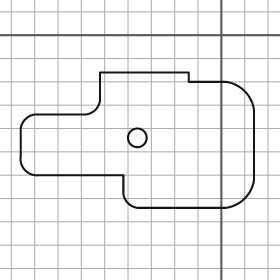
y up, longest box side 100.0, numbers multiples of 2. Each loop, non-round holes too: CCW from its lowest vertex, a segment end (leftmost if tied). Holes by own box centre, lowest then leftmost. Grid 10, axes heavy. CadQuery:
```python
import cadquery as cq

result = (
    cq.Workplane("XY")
    .moveTo(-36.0, -74.0)
    .lineTo(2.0, -74.0)
    .threePointArc((10.0, -70.0), (14.0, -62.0))
    .lineTo(14.0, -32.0)
    .threePointArc((10.0, -24.0), (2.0, -20.0))
    .lineTo(-14.0, -20.0)
    .lineTo(-14.0, -16.0)
    .lineTo(-52.0, -16.0)
    .lineTo(-52.0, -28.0)
    .threePointArc((-54.0, -32.0), (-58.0, -34.0))
    .lineTo(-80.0, -34.0)
    .threePointArc((-84.0, -36.0), (-86.0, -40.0))
    .lineTo(-86.0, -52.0)
    .threePointArc((-84.0, -58.0), (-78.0, -60.0))
    .lineTo(-42.0, -60.0)
    .lineTo(-42.0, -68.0)
    .threePointArc((-40.0, -72.0), (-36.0, -74.0))
    .close()
    .moveTo(-36.0, -44.0)
    .circle(4.0)
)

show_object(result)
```